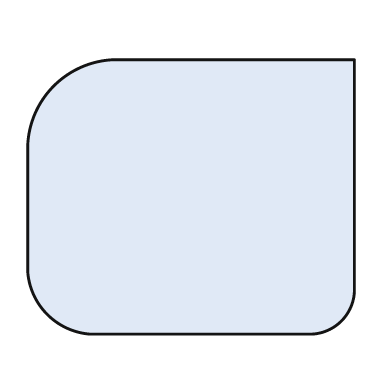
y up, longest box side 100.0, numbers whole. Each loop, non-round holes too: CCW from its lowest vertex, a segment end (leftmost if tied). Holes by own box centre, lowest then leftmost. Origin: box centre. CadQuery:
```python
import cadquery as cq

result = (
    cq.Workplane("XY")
    .moveTo(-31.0, -42.0)
    .lineTo(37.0, -42.0)
    .threePointArc((46.0, -38.0), (50.0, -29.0))
    .lineTo(50.0, 42.0)
    .lineTo(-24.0, 42.0)
    .threePointArc((-42.0, 34.0), (-50.0, 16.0))
    .lineTo(-50.0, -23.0)
    .threePointArc((-44.0, -36.0), (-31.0, -42.0))
    .close()
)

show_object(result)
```